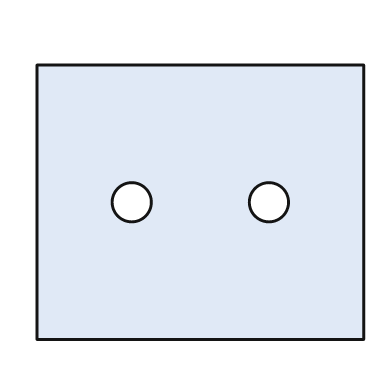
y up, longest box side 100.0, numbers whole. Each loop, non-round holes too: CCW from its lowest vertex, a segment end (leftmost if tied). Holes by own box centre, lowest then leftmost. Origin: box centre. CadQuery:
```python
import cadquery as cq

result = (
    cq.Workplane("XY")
    .moveTo(-50.0, -42.0)
    .lineTo(50.0, -42.0)
    .lineTo(50.0, 42.0)
    .lineTo(-50.0, 42.0)
    .close()
    .moveTo(-21.0, 0.0)
    .circle(6.0)
    .moveTo(21.0, 0.0)
    .circle(6.0)
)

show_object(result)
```